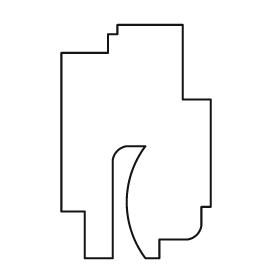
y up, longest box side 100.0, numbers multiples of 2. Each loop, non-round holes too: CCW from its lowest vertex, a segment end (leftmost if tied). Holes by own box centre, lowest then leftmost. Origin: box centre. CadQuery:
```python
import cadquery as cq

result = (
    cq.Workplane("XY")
    .moveTo(-22.0, -50.0)
    .lineTo(-10.0, -50.0)
    .lineTo(-10.0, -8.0)
    .threePointArc((-8.0, -4.0), (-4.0, -2.0))
    .lineTo(4.0, -2.0)
    .threePointArc((-4.0, -26.0), (4.0, -50.0))
    .lineTo(10.0, -50.0)
    .lineTo(10.0, -42.0)
    .lineTo(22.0, -42.0)
    .threePointArc((26.0, -40.0), (28.0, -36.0))
    .lineTo(28.0, -28.0)
    .lineTo(32.0, -28.0)
    .lineTo(32.0, 18.0)
    .lineTo(20.0, 18.0)
    .lineTo(20.0, 50.0)
    .lineTo(-8.0, 50.0)
    .lineTo(-8.0, 46.0)
    .lineTo(-12.0, 46.0)
    .lineTo(-12.0, 38.0)
    .lineTo(-32.0, 38.0)
    .lineTo(-32.0, -30.0)
    .lineTo(-22.0, -30.0)
    .close()
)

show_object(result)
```